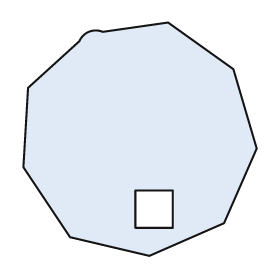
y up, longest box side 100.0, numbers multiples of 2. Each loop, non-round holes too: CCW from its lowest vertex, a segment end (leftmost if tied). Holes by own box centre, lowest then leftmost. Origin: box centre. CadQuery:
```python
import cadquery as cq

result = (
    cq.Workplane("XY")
    .moveTo(4.0, -50.0)
    .lineTo(36.0, -36.0)
    .lineTo(50.0, -4.0)
    .lineTo(40.0, 30.0)
    .lineTo(12.0, 50.0)
    .lineTo(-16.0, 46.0)
    .threePointArc((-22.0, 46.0), (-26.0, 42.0))
    .lineTo(-48.0, 22.0)
    .lineTo(-50.0, -12.0)
    .lineTo(-30.0, -42.0)
    .close()
    .moveTo(-2.0, -38.0)
    .lineTo(14.0, -38.0)
    .lineTo(14.0, -22.0)
    .lineTo(-2.0, -22.0)
    .close()
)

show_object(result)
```